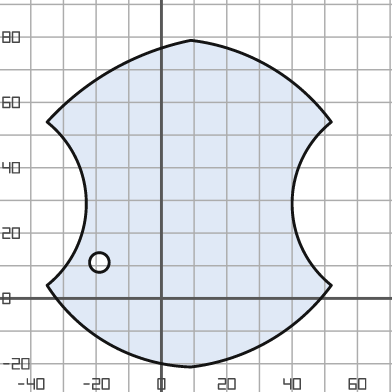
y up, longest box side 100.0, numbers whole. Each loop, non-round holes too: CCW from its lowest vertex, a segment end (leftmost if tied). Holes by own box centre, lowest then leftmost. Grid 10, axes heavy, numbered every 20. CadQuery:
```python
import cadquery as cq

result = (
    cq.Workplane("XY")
    .moveTo(9.0, -21.0)
    .threePointArc((33.0, -13.0), (52.0, 4.0))
    .threePointArc((40.0, 29.0), (52.0, 54.0))
    .threePointArc((33.0, 71.0), (9.0, 79.0))
    .threePointArc((-15.0, 70.0), (-35.0, 54.0))
    .threePointArc((-23.0, 29.0), (-35.0, 4.0))
    .threePointArc((-16.0, -14.0), (9.0, -21.0))
    .close()
    .moveTo(-19.0, 11.0)
    .circle(3.0)
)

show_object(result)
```